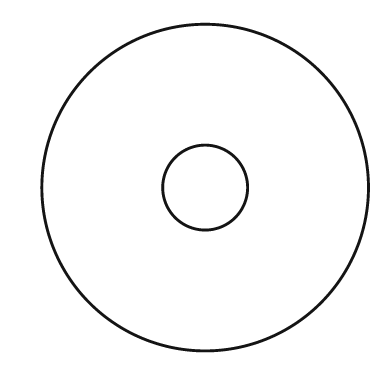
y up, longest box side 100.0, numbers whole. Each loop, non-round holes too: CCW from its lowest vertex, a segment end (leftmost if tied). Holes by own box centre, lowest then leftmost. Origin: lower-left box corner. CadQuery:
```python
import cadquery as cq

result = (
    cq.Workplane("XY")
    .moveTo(50.0, 50.0)
    .circle(50.0)
    .moveTo(50.0, 50.0)
    .circle(13.0)
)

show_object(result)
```